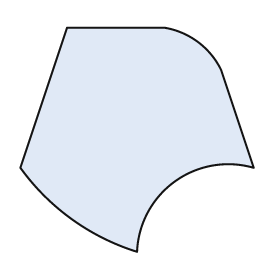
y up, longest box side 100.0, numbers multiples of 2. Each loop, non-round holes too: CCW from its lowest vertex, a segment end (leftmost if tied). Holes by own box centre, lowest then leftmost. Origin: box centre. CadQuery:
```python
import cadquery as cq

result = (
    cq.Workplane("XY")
    .moveTo(0.0, -48.0)
    .threePointArc((16.0, -18.0), (50.0, -12.0))
    .lineTo(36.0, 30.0)
    .threePointArc((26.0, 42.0), (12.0, 48.0))
    .lineTo(-30.0, 48.0)
    .lineTo(-50.0, -12.0)
    .threePointArc((-28.0, -34.0), (0.0, -48.0))
    .close()
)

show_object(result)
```